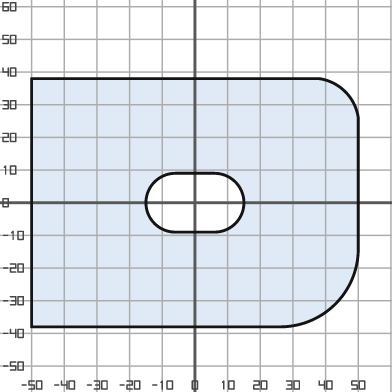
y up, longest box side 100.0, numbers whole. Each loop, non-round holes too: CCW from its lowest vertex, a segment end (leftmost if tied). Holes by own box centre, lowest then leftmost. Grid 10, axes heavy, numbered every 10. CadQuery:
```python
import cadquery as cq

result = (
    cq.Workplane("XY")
    .moveTo(-50.0, -38.0)
    .lineTo(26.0, -38.0)
    .threePointArc((43.0, -31.0), (50.0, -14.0))
    .lineTo(50.0, 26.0)
    .threePointArc((46.0, 34.0), (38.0, 38.0))
    .lineTo(-50.0, 38.0)
    .close()
    .moveTo(-6.0, -9.0)
    .lineTo(6.0, -9.0)
    .threePointArc((15.0, 0.0), (6.0, 9.0))
    .lineTo(-6.0, 9.0)
    .threePointArc((-15.0, 0.0), (-6.0, -9.0))
    .close()
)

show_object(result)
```